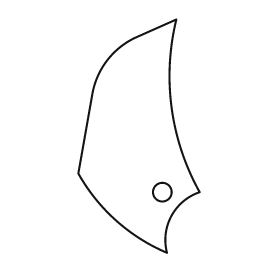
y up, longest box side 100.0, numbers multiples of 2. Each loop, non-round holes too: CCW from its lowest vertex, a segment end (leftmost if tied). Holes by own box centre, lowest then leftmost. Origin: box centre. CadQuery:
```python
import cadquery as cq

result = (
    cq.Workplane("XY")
    .moveTo(12.0, -50.0)
    .threePointArc((14.0, -34.0), (26.0, -24.0))
    .threePointArc((14.0, 12.0), (16.0, 50.0))
    .lineTo(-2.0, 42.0)
    .threePointArc((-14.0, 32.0), (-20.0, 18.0))
    .lineTo(-26.0, -16.0)
    .threePointArc((-10.0, -36.0), (12.0, -50.0))
    .close()
    .moveTo(10.0, -24.0)
    .circle(4.0)
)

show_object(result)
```